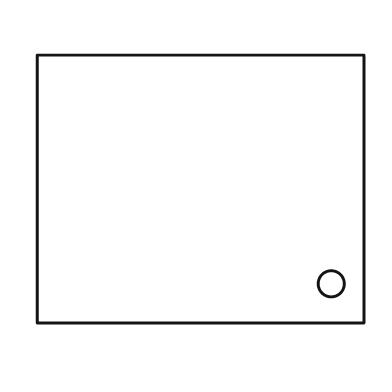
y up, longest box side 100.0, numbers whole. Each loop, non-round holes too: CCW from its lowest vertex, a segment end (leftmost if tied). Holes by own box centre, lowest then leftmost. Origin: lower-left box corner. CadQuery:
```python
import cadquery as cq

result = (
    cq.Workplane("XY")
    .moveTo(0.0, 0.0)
    .lineTo(100.0, 0.0)
    .lineTo(100.0, 82.0)
    .lineTo(0.0, 82.0)
    .close()
    .moveTo(90.0, 12.0)
    .circle(4.0)
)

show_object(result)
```